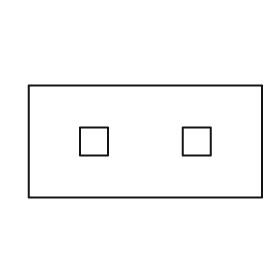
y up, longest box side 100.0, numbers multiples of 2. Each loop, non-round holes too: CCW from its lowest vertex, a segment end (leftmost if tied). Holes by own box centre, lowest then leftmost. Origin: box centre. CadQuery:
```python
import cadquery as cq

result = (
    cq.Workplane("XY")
    .moveTo(-50.0, -24.0)
    .lineTo(50.0, -24.0)
    .lineTo(50.0, 24.0)
    .lineTo(-50.0, 24.0)
    .close()
    .moveTo(-28.0, -6.0)
    .lineTo(-16.0, -6.0)
    .lineTo(-16.0, 6.0)
    .lineTo(-28.0, 6.0)
    .close()
    .moveTo(16.0, -6.0)
    .lineTo(28.0, -6.0)
    .lineTo(28.0, 6.0)
    .lineTo(16.0, 6.0)
    .close()
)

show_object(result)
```